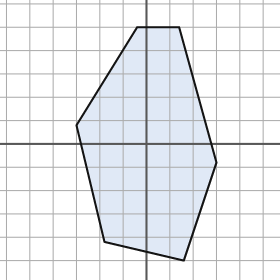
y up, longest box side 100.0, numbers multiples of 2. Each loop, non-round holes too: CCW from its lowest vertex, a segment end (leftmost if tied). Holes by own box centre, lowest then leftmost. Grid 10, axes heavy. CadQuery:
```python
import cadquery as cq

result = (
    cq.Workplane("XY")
    .moveTo(16.0, -50.0)
    .lineTo(30.0, -8.0)
    .lineTo(14.0, 50.0)
    .lineTo(-4.0, 50.0)
    .lineTo(-30.0, 8.0)
    .lineTo(-18.0, -42.0)
    .close()
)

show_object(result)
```